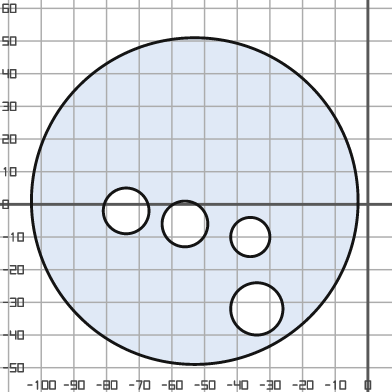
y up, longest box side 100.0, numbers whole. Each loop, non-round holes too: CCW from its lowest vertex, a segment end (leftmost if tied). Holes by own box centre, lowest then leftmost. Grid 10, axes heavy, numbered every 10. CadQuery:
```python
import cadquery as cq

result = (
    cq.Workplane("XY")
    .moveTo(-53.0, 1.0)
    .circle(50.0)
    .moveTo(-34.0, -32.0)
    .circle(8.0)
    .moveTo(-36.0, -10.0)
    .circle(6.0)
    .moveTo(-56.0, -6.0)
    .circle(7.0)
    .moveTo(-74.0, -2.0)
    .circle(7.0)
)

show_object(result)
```